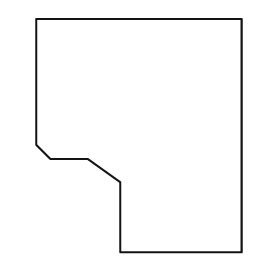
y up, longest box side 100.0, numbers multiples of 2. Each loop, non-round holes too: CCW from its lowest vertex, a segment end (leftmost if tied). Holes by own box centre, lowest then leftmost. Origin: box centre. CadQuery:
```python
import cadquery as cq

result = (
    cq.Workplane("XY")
    .moveTo(-8.0, -50.0)
    .lineTo(44.0, -50.0)
    .lineTo(44.0, 50.0)
    .lineTo(-44.0, 50.0)
    .lineTo(-44.0, -4.0)
    .lineTo(-38.0, -10.0)
    .lineTo(-22.0, -10.0)
    .lineTo(-8.0, -20.0)
    .close()
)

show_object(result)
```